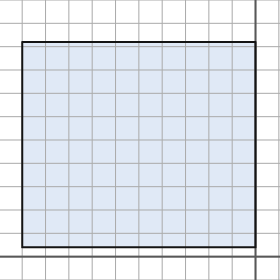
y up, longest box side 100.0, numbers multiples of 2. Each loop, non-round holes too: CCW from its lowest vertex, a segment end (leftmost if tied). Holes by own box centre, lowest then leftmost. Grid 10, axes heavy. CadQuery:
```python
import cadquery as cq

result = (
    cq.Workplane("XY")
    .moveTo(-100.0, 4.0)
    .lineTo(0.0, 4.0)
    .lineTo(0.0, 92.0)
    .lineTo(-100.0, 92.0)
    .close()
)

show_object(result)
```